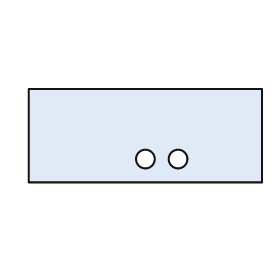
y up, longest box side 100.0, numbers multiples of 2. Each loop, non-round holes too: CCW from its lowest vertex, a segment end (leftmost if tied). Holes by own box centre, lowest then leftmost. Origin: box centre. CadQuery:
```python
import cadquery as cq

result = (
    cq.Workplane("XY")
    .moveTo(-50.0, -20.0)
    .lineTo(50.0, -20.0)
    .lineTo(50.0, 20.0)
    .lineTo(-50.0, 20.0)
    .close()
    .moveTo(0.0, -10.0)
    .circle(4.0)
    .moveTo(14.0, -10.0)
    .circle(4.0)
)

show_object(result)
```